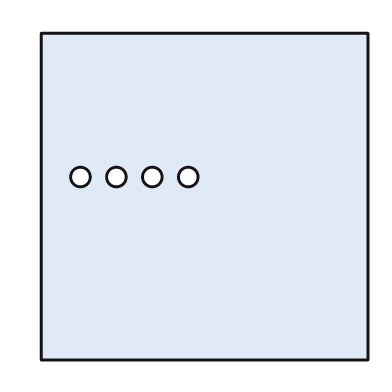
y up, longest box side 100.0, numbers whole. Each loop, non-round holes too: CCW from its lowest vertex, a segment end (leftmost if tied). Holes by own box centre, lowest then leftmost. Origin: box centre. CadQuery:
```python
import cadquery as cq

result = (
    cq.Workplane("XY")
    .moveTo(-50.0, -50.0)
    .lineTo(50.0, -50.0)
    .lineTo(50.0, 50.0)
    .lineTo(-50.0, 50.0)
    .close()
    .moveTo(-38.0, 6.0)
    .circle(3.0)
    .moveTo(-27.0, 6.0)
    .circle(3.0)
    .moveTo(-16.0, 6.0)
    .circle(3.0)
    .moveTo(-5.0, 6.0)
    .circle(3.0)
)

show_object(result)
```